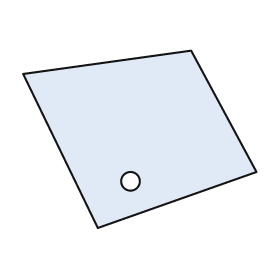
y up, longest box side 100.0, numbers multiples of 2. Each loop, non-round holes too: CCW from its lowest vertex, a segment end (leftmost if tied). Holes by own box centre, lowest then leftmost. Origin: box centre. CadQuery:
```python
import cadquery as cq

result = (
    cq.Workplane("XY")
    .moveTo(-18.0, -38.0)
    .lineTo(50.0, -14.0)
    .lineTo(22.0, 38.0)
    .lineTo(-50.0, 28.0)
    .close()
    .moveTo(-4.0, -18.0)
    .circle(4.0)
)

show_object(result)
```